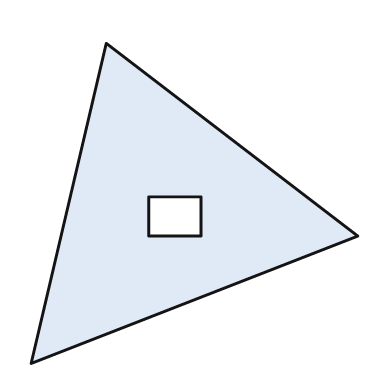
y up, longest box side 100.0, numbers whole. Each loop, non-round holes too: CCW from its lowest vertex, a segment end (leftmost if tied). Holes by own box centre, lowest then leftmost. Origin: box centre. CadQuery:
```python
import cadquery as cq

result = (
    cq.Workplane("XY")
    .moveTo(-50.0, -49.0)
    .lineTo(50.0, -10.0)
    .lineTo(-27.0, 49.0)
    .close()
    .moveTo(-14.0, -10.0)
    .lineTo(2.0, -10.0)
    .lineTo(2.0, 2.0)
    .lineTo(-14.0, 2.0)
    .close()
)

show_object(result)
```